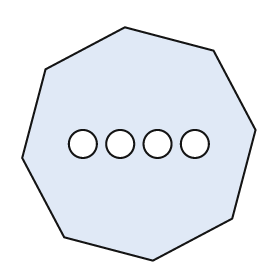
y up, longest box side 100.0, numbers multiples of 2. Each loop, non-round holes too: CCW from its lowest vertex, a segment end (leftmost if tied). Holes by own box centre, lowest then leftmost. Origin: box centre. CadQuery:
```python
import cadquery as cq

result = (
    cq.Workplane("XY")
    .moveTo(6.0, -50.0)
    .lineTo(40.0, -32.0)
    .lineTo(50.0, 6.0)
    .lineTo(32.0, 40.0)
    .lineTo(-6.0, 50.0)
    .lineTo(-40.0, 32.0)
    .lineTo(-50.0, -6.0)
    .lineTo(-32.0, -40.0)
    .close()
    .moveTo(-24.0, 0.0)
    .circle(6.0)
    .moveTo(-8.0, 0.0)
    .circle(6.0)
    .moveTo(8.0, 0.0)
    .circle(6.0)
    .moveTo(24.0, 0.0)
    .circle(6.0)
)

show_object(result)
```